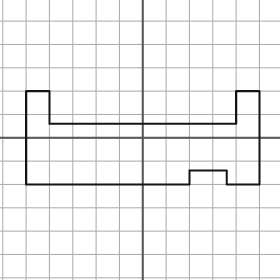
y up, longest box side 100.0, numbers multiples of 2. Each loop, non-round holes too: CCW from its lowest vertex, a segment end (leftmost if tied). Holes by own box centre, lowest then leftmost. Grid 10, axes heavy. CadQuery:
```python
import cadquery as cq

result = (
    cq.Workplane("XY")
    .moveTo(-50.0, -20.0)
    .lineTo(20.0, -20.0)
    .lineTo(20.0, -14.0)
    .lineTo(36.0, -14.0)
    .lineTo(36.0, -20.0)
    .lineTo(50.0, -20.0)
    .lineTo(50.0, 20.0)
    .lineTo(40.0, 20.0)
    .lineTo(40.0, 6.0)
    .lineTo(-40.0, 6.0)
    .lineTo(-40.0, 20.0)
    .lineTo(-50.0, 20.0)
    .close()
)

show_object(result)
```